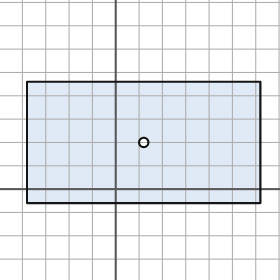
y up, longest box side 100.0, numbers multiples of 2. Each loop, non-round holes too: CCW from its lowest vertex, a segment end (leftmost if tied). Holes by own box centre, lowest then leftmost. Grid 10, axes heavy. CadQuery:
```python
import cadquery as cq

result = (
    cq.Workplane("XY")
    .moveTo(-38.0, -6.0)
    .lineTo(62.0, -6.0)
    .lineTo(62.0, 46.0)
    .lineTo(-38.0, 46.0)
    .close()
    .moveTo(12.0, 20.0)
    .circle(2.0)
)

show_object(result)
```